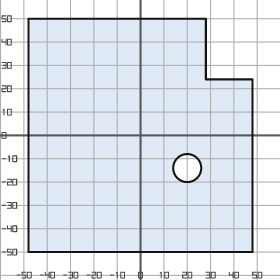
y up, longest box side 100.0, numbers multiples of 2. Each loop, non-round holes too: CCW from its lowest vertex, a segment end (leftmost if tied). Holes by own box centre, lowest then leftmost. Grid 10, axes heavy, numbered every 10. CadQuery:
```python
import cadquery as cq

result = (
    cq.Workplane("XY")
    .moveTo(-48.0, -50.0)
    .lineTo(48.0, -50.0)
    .lineTo(48.0, 24.0)
    .lineTo(28.0, 24.0)
    .lineTo(28.0, 50.0)
    .lineTo(-48.0, 50.0)
    .close()
    .moveTo(20.0, -14.0)
    .circle(6.0)
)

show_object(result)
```